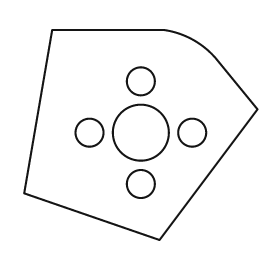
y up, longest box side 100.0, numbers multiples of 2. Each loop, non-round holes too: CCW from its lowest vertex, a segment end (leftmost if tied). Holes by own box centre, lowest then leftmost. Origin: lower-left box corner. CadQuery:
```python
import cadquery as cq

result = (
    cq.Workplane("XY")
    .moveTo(58.0, 0.0)
    .lineTo(100.0, 56.0)
    .lineTo(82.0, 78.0)
    .threePointArc((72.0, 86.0), (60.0, 90.0))
    .lineTo(12.0, 90.0)
    .lineTo(0.0, 20.0)
    .close()
    .moveTo(50.0, 24.0)
    .circle(6.0)
    .moveTo(28.0, 46.0)
    .circle(6.0)
    .moveTo(50.0, 46.0)
    .circle(12.0)
    .moveTo(72.0, 46.0)
    .circle(6.0)
    .moveTo(50.0, 68.0)
    .circle(6.0)
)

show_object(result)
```